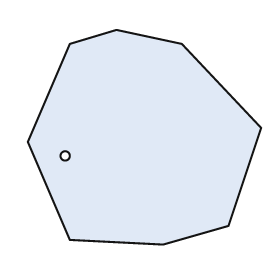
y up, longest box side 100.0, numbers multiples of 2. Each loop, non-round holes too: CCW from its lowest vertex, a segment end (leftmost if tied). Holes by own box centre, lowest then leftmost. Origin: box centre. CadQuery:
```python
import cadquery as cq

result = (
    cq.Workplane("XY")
    .moveTo(8.0, -46.0)
    .lineTo(36.0, -38.0)
    .lineTo(50.0, 4.0)
    .lineTo(16.0, 40.0)
    .lineTo(-12.0, 46.0)
    .lineTo(-32.0, 40.0)
    .lineTo(-50.0, -2.0)
    .lineTo(-32.0, -44.0)
    .close()
    .moveTo(-34.0, -8.0)
    .circle(2.0)
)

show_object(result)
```